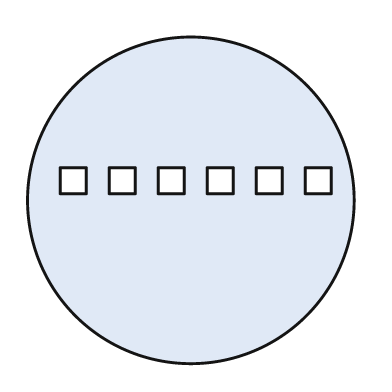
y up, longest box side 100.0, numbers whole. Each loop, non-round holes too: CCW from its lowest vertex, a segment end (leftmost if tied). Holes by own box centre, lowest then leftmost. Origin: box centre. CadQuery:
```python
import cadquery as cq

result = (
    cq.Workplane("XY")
    .moveTo(0.0, 0.0)
    .circle(50.0)
    .moveTo(-40.0, 2.0)
    .lineTo(-32.0, 2.0)
    .lineTo(-32.0, 10.0)
    .lineTo(-40.0, 10.0)
    .close()
    .moveTo(-25.0, 2.0)
    .lineTo(-17.0, 2.0)
    .lineTo(-17.0, 10.0)
    .lineTo(-25.0, 10.0)
    .close()
    .moveTo(-10.0, 2.0)
    .lineTo(-2.0, 2.0)
    .lineTo(-2.0, 10.0)
    .lineTo(-10.0, 10.0)
    .close()
    .moveTo(5.0, 2.0)
    .lineTo(13.0, 2.0)
    .lineTo(13.0, 10.0)
    .lineTo(5.0, 10.0)
    .close()
    .moveTo(20.0, 2.0)
    .lineTo(28.0, 2.0)
    .lineTo(28.0, 10.0)
    .lineTo(20.0, 10.0)
    .close()
    .moveTo(35.0, 2.0)
    .lineTo(43.0, 2.0)
    .lineTo(43.0, 10.0)
    .lineTo(35.0, 10.0)
    .close()
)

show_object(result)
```